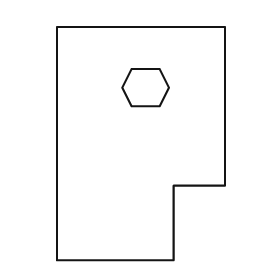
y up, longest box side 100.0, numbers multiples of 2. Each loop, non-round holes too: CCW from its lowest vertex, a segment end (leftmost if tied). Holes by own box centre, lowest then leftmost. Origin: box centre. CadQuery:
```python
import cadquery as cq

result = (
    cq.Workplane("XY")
    .moveTo(-36.0, -50.0)
    .lineTo(14.0, -50.0)
    .lineTo(14.0, -18.0)
    .lineTo(36.0, -18.0)
    .lineTo(36.0, 50.0)
    .lineTo(-36.0, 50.0)
    .close()
    .moveTo(-4.0, 16.0)
    .lineTo(8.0, 16.0)
    .lineTo(12.0, 24.0)
    .lineTo(8.0, 32.0)
    .lineTo(-4.0, 32.0)
    .lineTo(-8.0, 24.0)
    .close()
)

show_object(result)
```